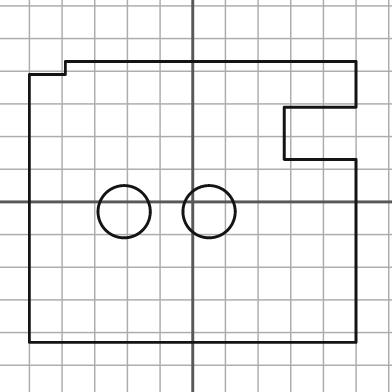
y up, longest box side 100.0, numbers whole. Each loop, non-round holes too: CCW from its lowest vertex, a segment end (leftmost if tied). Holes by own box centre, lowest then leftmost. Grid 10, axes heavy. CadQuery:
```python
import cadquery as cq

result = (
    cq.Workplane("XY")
    .moveTo(-50.0, -43.0)
    .lineTo(50.0, -43.0)
    .lineTo(50.0, 13.0)
    .lineTo(28.0, 13.0)
    .lineTo(28.0, 29.0)
    .lineTo(50.0, 29.0)
    .lineTo(50.0, 43.0)
    .lineTo(-39.0, 43.0)
    .lineTo(-39.0, 39.0)
    .lineTo(-50.0, 39.0)
    .close()
    .moveTo(-21.0, -3.0)
    .circle(8.0)
    .moveTo(5.0, -3.0)
    .circle(8.0)
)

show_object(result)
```